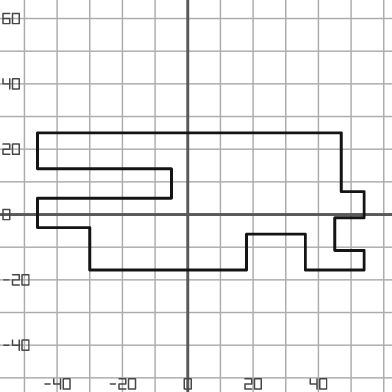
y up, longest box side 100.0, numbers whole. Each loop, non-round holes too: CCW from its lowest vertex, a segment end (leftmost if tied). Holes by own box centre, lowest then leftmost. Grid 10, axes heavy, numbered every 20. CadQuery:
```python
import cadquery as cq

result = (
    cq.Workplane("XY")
    .moveTo(-30.0, -17.0)
    .lineTo(18.0, -17.0)
    .lineTo(18.0, -6.0)
    .lineTo(36.0, -6.0)
    .lineTo(36.0, -17.0)
    .lineTo(54.0, -17.0)
    .lineTo(54.0, -11.0)
    .lineTo(45.0, -11.0)
    .lineTo(45.0, -1.0)
    .lineTo(54.0, -1.0)
    .lineTo(54.0, 7.0)
    .lineTo(47.0, 7.0)
    .lineTo(47.0, 25.0)
    .lineTo(-46.0, 25.0)
    .lineTo(-46.0, 14.0)
    .lineTo(-5.0, 14.0)
    .lineTo(-5.0, 5.0)
    .lineTo(-46.0, 5.0)
    .lineTo(-46.0, -4.0)
    .lineTo(-30.0, -4.0)
    .close()
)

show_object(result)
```